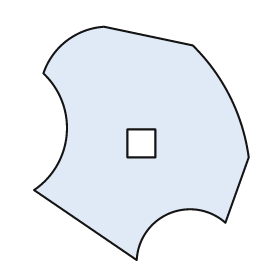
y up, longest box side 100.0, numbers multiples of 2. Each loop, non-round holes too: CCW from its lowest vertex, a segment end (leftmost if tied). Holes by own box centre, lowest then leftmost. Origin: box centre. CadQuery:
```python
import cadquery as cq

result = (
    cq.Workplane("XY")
    .moveTo(-2.0, -50.0)
    .threePointArc((12.0, -30.0), (36.0, -34.0))
    .lineTo(46.0, -6.0)
    .threePointArc((38.0, 20.0), (22.0, 42.0))
    .lineTo(-16.0, 50.0)
    .threePointArc((-32.0, 44.0), (-42.0, 30.0))
    .threePointArc((-32.0, 4.0), (-46.0, -20.0))
    .close()
    .moveTo(-6.0, -6.0)
    .lineTo(6.0, -6.0)
    .lineTo(6.0, 6.0)
    .lineTo(-6.0, 6.0)
    .close()
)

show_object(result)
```